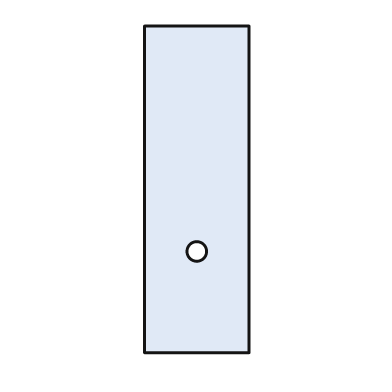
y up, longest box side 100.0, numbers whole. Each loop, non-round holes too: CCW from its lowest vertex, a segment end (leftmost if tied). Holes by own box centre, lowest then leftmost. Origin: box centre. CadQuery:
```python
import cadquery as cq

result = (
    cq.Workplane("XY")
    .moveTo(-16.0, -50.0)
    .lineTo(16.0, -50.0)
    .lineTo(16.0, 50.0)
    .lineTo(-16.0, 50.0)
    .close()
    .moveTo(0.0, -19.0)
    .circle(3.0)
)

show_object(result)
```